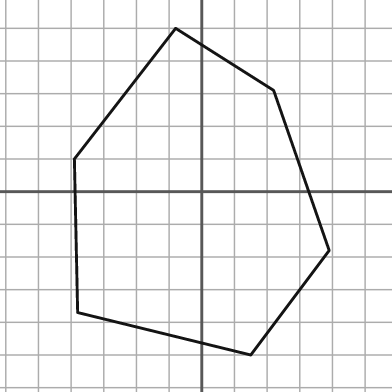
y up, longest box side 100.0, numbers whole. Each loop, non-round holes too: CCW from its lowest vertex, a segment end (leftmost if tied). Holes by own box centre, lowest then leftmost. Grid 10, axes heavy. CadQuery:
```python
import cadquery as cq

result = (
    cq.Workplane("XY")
    .moveTo(15.0, -50.0)
    .lineTo(39.0, -18.0)
    .lineTo(22.0, 31.0)
    .lineTo(-8.0, 50.0)
    .lineTo(-39.0, 10.0)
    .lineTo(-38.0, -37.0)
    .close()
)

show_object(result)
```